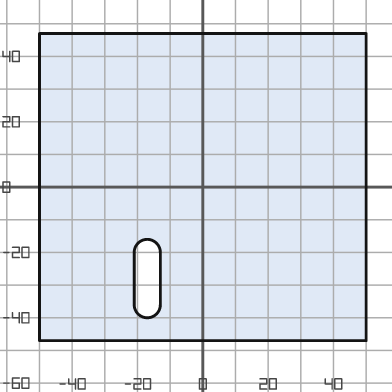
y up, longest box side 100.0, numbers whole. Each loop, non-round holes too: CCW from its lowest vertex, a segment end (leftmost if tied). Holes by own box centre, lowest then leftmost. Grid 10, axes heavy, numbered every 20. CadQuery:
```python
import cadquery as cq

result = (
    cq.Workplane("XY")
    .moveTo(-50.0, -47.0)
    .lineTo(50.0, -47.0)
    .lineTo(50.0, 47.0)
    .lineTo(-50.0, 47.0)
    .close()
    .moveTo(-21.0, -36.0)
    .threePointArc((-17.0, -40.0), (-13.0, -36.0))
    .lineTo(-13.0, -20.0)
    .threePointArc((-17.0, -16.0), (-21.0, -20.0))
    .close()
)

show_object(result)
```